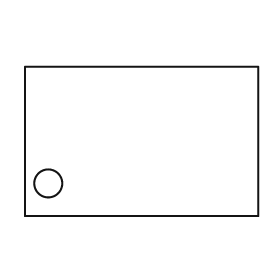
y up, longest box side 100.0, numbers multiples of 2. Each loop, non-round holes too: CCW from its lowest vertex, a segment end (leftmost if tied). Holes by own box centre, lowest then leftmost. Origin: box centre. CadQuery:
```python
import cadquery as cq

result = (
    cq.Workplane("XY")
    .moveTo(-50.0, -32.0)
    .lineTo(50.0, -32.0)
    .lineTo(50.0, 32.0)
    .lineTo(-50.0, 32.0)
    .close()
    .moveTo(-40.0, -18.0)
    .circle(6.0)
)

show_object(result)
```